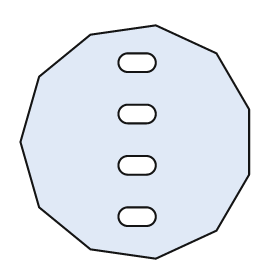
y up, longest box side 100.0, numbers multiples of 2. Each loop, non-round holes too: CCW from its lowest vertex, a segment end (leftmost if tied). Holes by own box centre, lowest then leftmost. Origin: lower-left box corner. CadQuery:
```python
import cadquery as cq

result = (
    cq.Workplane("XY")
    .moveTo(58.0, 0.0)
    .lineTo(84.0, 12.0)
    .lineTo(98.0, 36.0)
    .lineTo(98.0, 64.0)
    .lineTo(84.0, 88.0)
    .lineTo(58.0, 100.0)
    .lineTo(30.0, 96.0)
    .lineTo(8.0, 78.0)
    .lineTo(0.0, 50.0)
    .lineTo(8.0, 22.0)
    .lineTo(30.0, 4.0)
    .close()
    .moveTo(46.0, 14.0)
    .lineTo(54.0, 14.0)
    .threePointArc((58.0, 18.0), (54.0, 22.0))
    .lineTo(46.0, 22.0)
    .threePointArc((42.0, 18.0), (46.0, 14.0))
    .close()
    .moveTo(46.0, 36.0)
    .lineTo(54.0, 36.0)
    .threePointArc((58.0, 40.0), (54.0, 44.0))
    .lineTo(46.0, 44.0)
    .threePointArc((42.0, 40.0), (46.0, 36.0))
    .close()
    .moveTo(46.0, 58.0)
    .lineTo(54.0, 58.0)
    .threePointArc((58.0, 62.0), (54.0, 66.0))
    .lineTo(46.0, 66.0)
    .threePointArc((42.0, 62.0), (46.0, 58.0))
    .close()
    .moveTo(46.0, 80.0)
    .lineTo(54.0, 80.0)
    .threePointArc((58.0, 84.0), (54.0, 88.0))
    .lineTo(46.0, 88.0)
    .threePointArc((42.0, 84.0), (46.0, 80.0))
    .close()
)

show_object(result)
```